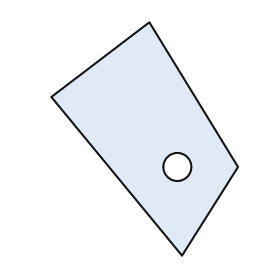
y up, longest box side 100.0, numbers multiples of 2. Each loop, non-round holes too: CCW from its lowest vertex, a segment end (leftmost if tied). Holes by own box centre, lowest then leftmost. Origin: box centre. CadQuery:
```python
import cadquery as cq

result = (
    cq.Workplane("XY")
    .moveTo(16.0, -50.0)
    .lineTo(40.0, -12.0)
    .lineTo(2.0, 50.0)
    .lineTo(-40.0, 18.0)
    .close()
    .moveTo(14.0, -12.0)
    .circle(6.0)
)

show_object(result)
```